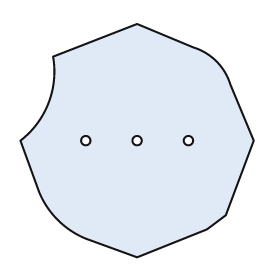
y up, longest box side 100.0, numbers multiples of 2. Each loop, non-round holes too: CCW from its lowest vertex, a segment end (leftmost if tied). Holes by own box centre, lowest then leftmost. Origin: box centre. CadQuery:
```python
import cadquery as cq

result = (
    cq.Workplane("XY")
    .moveTo(0.0, -50.0)
    .lineTo(30.0, -38.0)
    .lineTo(38.0, -32.0)
    .lineTo(50.0, 0.0)
    .lineTo(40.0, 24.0)
    .threePointArc((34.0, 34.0), (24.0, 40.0))
    .lineTo(0.0, 50.0)
    .lineTo(-36.0, 36.0)
    .threePointArc((-38.0, 16.0), (-50.0, 0.0))
    .lineTo(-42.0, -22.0)
    .threePointArc((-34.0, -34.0), (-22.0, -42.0))
    .close()
    .moveTo(-22.0, 0.0)
    .circle(2.0)
    .moveTo(0.0, 0.0)
    .circle(2.0)
    .moveTo(22.0, 0.0)
    .circle(2.0)
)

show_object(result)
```